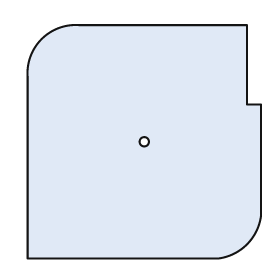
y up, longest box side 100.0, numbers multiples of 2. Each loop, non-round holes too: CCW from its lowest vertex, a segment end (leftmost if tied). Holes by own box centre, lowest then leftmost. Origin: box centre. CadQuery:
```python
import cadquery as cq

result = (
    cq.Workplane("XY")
    .moveTo(-50.0, -50.0)
    .lineTo(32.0, -50.0)
    .threePointArc((44.0, -44.0), (50.0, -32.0))
    .lineTo(50.0, 16.0)
    .lineTo(44.0, 16.0)
    .lineTo(44.0, 50.0)
    .lineTo(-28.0, 50.0)
    .threePointArc((-44.0, 44.0), (-50.0, 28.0))
    .close()
    .moveTo(0.0, 0.0)
    .circle(2.0)
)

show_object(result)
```